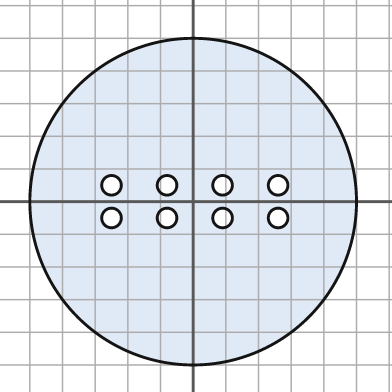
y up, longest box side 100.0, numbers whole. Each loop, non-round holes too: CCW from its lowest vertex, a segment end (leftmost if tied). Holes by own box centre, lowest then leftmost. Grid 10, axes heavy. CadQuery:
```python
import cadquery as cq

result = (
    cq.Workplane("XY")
    .moveTo(0.0, 0.0)
    .circle(50.0)
    .moveTo(-25.0, -5.0)
    .circle(3.0)
    .moveTo(-8.0, -5.0)
    .circle(3.0)
    .moveTo(9.0, -5.0)
    .circle(3.0)
    .moveTo(26.0, -5.0)
    .circle(3.0)
    .moveTo(-25.0, 5.0)
    .circle(3.0)
    .moveTo(-8.0, 5.0)
    .circle(3.0)
    .moveTo(9.0, 5.0)
    .circle(3.0)
    .moveTo(26.0, 5.0)
    .circle(3.0)
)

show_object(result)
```